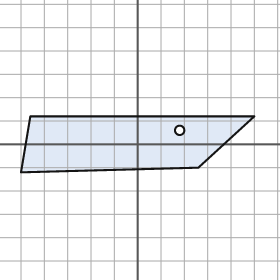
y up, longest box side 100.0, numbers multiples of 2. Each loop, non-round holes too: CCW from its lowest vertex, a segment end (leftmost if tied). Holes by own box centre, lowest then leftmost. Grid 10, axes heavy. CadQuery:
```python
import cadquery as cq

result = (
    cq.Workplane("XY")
    .moveTo(-50.0, -12.0)
    .lineTo(26.0, -10.0)
    .lineTo(50.0, 12.0)
    .lineTo(-46.0, 12.0)
    .close()
    .moveTo(18.0, 6.0)
    .circle(2.0)
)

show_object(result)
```